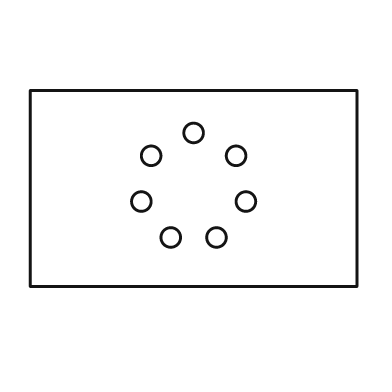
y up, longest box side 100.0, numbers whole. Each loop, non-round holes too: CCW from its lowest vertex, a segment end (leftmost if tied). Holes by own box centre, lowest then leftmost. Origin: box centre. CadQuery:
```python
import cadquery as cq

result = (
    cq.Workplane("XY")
    .moveTo(-50.0, -30.0)
    .lineTo(50.0, -30.0)
    .lineTo(50.0, 30.0)
    .lineTo(-50.0, 30.0)
    .close()
    .moveTo(-7.0, -15.0)
    .circle(3.0)
    .moveTo(7.0, -15.0)
    .circle(3.0)
    .moveTo(-16.0, -4.0)
    .circle(3.0)
    .moveTo(16.0, -4.0)
    .circle(3.0)
    .moveTo(-13.0, 10.0)
    .circle(3.0)
    .moveTo(13.0, 10.0)
    .circle(3.0)
    .moveTo(0.0, 17.0)
    .circle(3.0)
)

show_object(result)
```